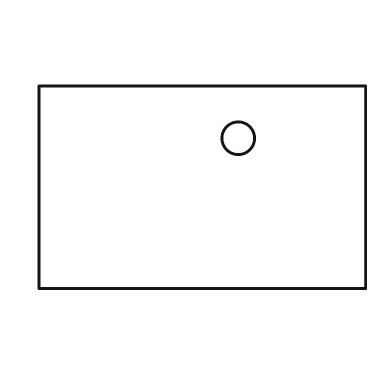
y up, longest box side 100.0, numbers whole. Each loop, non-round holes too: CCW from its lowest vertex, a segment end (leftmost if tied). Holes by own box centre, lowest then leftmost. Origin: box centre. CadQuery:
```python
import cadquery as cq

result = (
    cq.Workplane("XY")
    .moveTo(-50.0, -31.0)
    .lineTo(50.0, -31.0)
    .lineTo(50.0, 31.0)
    .lineTo(-50.0, 31.0)
    .close()
    .moveTo(11.0, 15.0)
    .circle(5.0)
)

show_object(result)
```